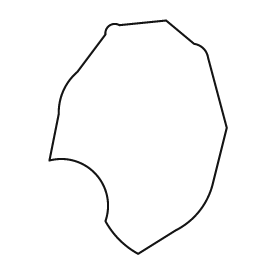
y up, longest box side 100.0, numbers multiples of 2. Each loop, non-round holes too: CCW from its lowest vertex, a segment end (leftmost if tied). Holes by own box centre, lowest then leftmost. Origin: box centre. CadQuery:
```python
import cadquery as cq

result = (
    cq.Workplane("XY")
    .moveTo(0.0, -50.0)
    .lineTo(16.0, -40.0)
    .threePointArc((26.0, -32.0), (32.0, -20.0))
    .lineTo(38.0, 4.0)
    .lineTo(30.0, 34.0)
    .threePointArc((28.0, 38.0), (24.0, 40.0))
    .lineTo(12.0, 50.0)
    .lineTo(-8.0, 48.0)
    .threePointArc((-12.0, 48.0), (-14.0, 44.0))
    .lineTo(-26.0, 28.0)
    .threePointArc((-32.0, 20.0), (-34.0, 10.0))
    .lineTo(-38.0, -10.0)
    .threePointArc((-18.0, -16.0), (-14.0, -36.0))
    .threePointArc((-8.0, -44.0), (0.0, -50.0))
    .close()
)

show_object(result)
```